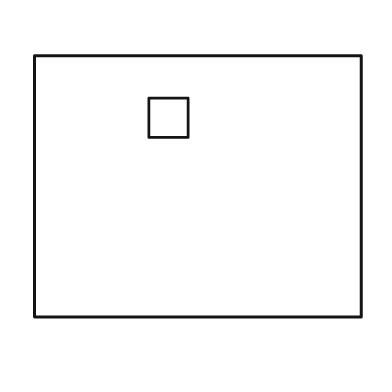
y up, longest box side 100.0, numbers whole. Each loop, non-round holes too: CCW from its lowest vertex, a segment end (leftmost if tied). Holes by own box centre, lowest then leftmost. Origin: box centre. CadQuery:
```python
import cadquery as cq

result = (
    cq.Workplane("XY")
    .moveTo(-50.0, -40.0)
    .lineTo(50.0, -40.0)
    .lineTo(50.0, 40.0)
    .lineTo(-50.0, 40.0)
    .close()
    .moveTo(-15.0, 15.0)
    .lineTo(-3.0, 15.0)
    .lineTo(-3.0, 27.0)
    .lineTo(-15.0, 27.0)
    .close()
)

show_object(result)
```